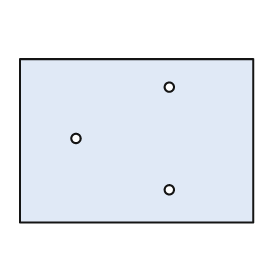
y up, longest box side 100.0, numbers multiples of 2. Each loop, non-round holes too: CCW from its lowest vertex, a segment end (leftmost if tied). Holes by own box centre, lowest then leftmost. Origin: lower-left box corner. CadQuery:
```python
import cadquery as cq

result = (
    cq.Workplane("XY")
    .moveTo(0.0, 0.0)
    .lineTo(100.0, 0.0)
    .lineTo(100.0, 70.0)
    .lineTo(0.0, 70.0)
    .close()
    .moveTo(64.0, 14.0)
    .circle(2.0)
    .moveTo(24.0, 36.0)
    .circle(2.0)
    .moveTo(64.0, 58.0)
    .circle(2.0)
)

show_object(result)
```